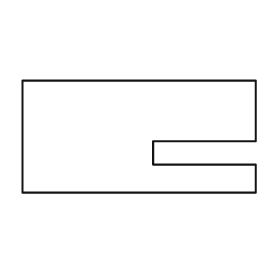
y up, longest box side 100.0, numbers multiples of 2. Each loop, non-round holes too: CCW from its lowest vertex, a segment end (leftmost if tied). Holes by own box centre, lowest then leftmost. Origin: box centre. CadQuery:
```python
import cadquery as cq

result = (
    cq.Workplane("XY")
    .moveTo(-50.0, -24.0)
    .lineTo(50.0, -24.0)
    .lineTo(50.0, -12.0)
    .lineTo(6.0, -12.0)
    .lineTo(6.0, -2.0)
    .lineTo(50.0, -2.0)
    .lineTo(50.0, 24.0)
    .lineTo(-50.0, 24.0)
    .close()
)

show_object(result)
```